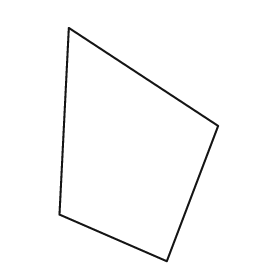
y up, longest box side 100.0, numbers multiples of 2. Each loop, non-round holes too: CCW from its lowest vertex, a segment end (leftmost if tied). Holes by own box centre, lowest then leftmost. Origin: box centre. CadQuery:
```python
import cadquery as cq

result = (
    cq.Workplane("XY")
    .moveTo(12.0, -50.0)
    .lineTo(34.0, 8.0)
    .lineTo(-30.0, 50.0)
    .lineTo(-34.0, -30.0)
    .close()
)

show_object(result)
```